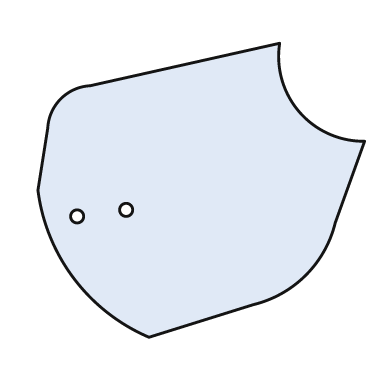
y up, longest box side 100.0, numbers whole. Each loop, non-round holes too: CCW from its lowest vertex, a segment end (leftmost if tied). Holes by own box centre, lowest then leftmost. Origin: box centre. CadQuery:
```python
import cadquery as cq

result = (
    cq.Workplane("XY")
    .moveTo(-16.0, -45.0)
    .lineTo(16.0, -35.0)
    .threePointArc((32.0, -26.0), (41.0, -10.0))
    .lineTo(50.0, 15.0)
    .threePointArc((30.0, 24.0), (24.0, 45.0))
    .lineTo(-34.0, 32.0)
    .threePointArc((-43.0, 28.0), (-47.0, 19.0))
    .lineTo(-50.0, 0.0)
    .threePointArc((-39.0, -27.0), (-16.0, -45.0))
    .close()
    .moveTo(-38.0, -8.0)
    .circle(2.0)
    .moveTo(-23.0, -6.0)
    .circle(2.0)
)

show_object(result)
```